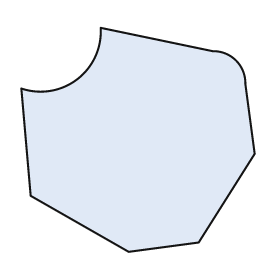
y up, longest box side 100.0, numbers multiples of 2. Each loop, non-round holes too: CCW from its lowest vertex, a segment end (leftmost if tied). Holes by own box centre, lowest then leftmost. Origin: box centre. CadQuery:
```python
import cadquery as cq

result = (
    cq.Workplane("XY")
    .moveTo(-4.0, -48.0)
    .lineTo(26.0, -44.0)
    .lineTo(50.0, -6.0)
    .lineTo(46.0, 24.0)
    .threePointArc((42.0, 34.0), (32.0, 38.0))
    .lineTo(-16.0, 48.0)
    .threePointArc((-26.0, 26.0), (-50.0, 22.0))
    .lineTo(-46.0, -24.0)
    .close()
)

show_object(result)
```